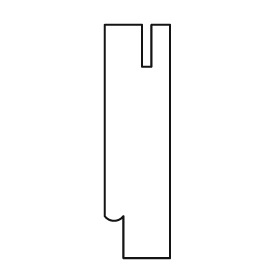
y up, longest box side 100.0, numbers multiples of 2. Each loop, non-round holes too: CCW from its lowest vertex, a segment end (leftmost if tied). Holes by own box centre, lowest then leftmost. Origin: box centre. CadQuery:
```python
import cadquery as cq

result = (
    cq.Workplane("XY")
    .moveTo(-6.0, -50.0)
    .lineTo(14.0, -50.0)
    .lineTo(14.0, 50.0)
    .lineTo(6.0, 50.0)
    .lineTo(6.0, 32.0)
    .lineTo(2.0, 32.0)
    .lineTo(2.0, 50.0)
    .lineTo(-14.0, 50.0)
    .lineTo(-14.0, -32.0)
    .threePointArc((-10.0, -34.0), (-6.0, -32.0))
    .close()
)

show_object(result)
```